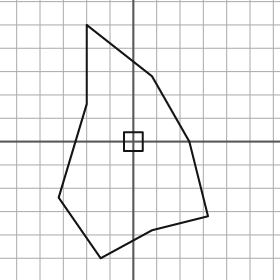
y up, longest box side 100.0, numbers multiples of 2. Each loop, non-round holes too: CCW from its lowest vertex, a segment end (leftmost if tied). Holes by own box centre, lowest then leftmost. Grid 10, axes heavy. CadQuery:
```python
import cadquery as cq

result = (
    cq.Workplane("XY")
    .moveTo(-14.0, -50.0)
    .lineTo(8.0, -38.0)
    .lineTo(32.0, -32.0)
    .lineTo(24.0, 0.0)
    .lineTo(8.0, 28.0)
    .lineTo(-20.0, 50.0)
    .lineTo(-20.0, 16.0)
    .lineTo(-32.0, -24.0)
    .close()
    .moveTo(-4.0, -4.0)
    .lineTo(4.0, -4.0)
    .lineTo(4.0, 4.0)
    .lineTo(-4.0, 4.0)
    .close()
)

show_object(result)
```